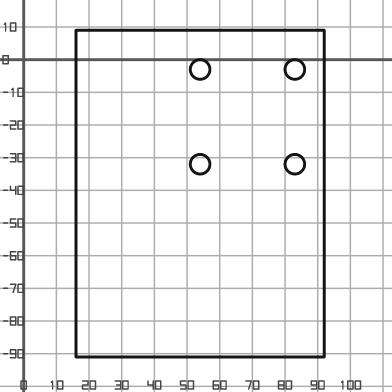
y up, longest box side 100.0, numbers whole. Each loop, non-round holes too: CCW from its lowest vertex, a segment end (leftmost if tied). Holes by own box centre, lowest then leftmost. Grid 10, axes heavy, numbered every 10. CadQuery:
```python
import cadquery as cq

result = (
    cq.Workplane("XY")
    .moveTo(16.0, -91.0)
    .lineTo(92.0, -91.0)
    .lineTo(92.0, 9.0)
    .lineTo(16.0, 9.0)
    .close()
    .moveTo(54.0, -32.0)
    .circle(3.0)
    .moveTo(83.0, -32.0)
    .circle(3.0)
    .moveTo(54.0, -3.0)
    .circle(3.0)
    .moveTo(83.0, -3.0)
    .circle(3.0)
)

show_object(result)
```